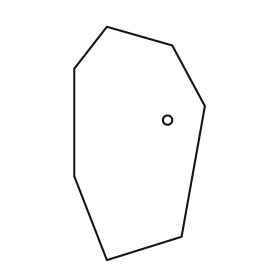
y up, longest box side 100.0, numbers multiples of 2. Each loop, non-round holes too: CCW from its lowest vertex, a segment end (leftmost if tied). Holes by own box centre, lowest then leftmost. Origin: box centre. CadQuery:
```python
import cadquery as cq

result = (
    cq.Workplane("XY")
    .moveTo(-14.0, -50.0)
    .lineTo(18.0, -40.0)
    .lineTo(28.0, 16.0)
    .lineTo(14.0, 42.0)
    .lineTo(-14.0, 50.0)
    .lineTo(-28.0, 32.0)
    .lineTo(-28.0, -14.0)
    .close()
    .moveTo(12.0, 10.0)
    .circle(2.0)
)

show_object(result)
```